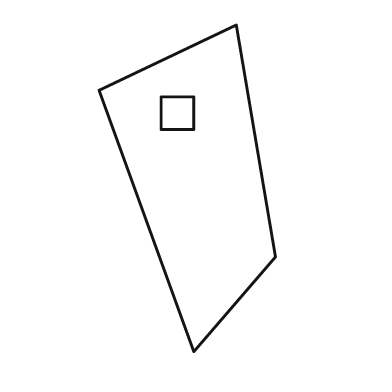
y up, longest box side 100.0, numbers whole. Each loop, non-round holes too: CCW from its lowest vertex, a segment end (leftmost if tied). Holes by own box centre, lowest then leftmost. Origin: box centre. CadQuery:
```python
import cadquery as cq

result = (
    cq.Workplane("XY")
    .moveTo(2.0, -50.0)
    .lineTo(27.0, -21.0)
    .lineTo(15.0, 50.0)
    .lineTo(-27.0, 30.0)
    .close()
    .moveTo(-8.0, 18.0)
    .lineTo(2.0, 18.0)
    .lineTo(2.0, 28.0)
    .lineTo(-8.0, 28.0)
    .close()
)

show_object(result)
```